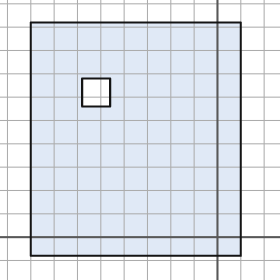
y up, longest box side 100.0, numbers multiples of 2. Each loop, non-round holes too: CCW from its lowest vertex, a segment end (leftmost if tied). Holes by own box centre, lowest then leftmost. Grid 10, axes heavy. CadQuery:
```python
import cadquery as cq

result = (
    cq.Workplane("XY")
    .moveTo(-80.0, -8.0)
    .lineTo(10.0, -8.0)
    .lineTo(10.0, 92.0)
    .lineTo(-80.0, 92.0)
    .close()
    .moveTo(-58.0, 56.0)
    .lineTo(-46.0, 56.0)
    .lineTo(-46.0, 68.0)
    .lineTo(-58.0, 68.0)
    .close()
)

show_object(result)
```